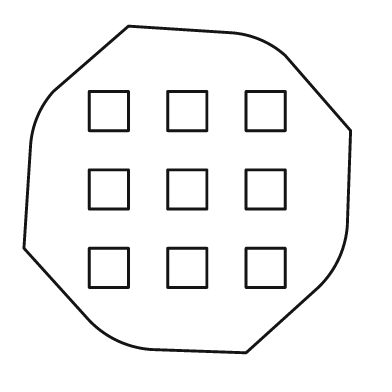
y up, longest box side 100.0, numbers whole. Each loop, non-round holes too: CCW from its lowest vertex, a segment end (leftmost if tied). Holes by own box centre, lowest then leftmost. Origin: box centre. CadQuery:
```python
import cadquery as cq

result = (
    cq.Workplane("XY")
    .moveTo(18.0, -50.0)
    .lineTo(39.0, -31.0)
    .threePointArc((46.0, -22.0), (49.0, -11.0))
    .lineTo(50.0, 18.0)
    .lineTo(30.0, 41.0)
    .threePointArc((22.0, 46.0), (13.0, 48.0))
    .lineTo(-18.0, 50.0)
    .lineTo(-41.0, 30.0)
    .threePointArc((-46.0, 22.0), (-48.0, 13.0))
    .lineTo(-50.0, -18.0)
    .lineTo(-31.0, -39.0)
    .threePointArc((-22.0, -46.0), (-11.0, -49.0))
    .close()
    .moveTo(-30.0, -30.0)
    .lineTo(-18.0, -30.0)
    .lineTo(-18.0, -18.0)
    .lineTo(-30.0, -18.0)
    .close()
    .moveTo(-6.0, -30.0)
    .lineTo(6.0, -30.0)
    .lineTo(6.0, -18.0)
    .lineTo(-6.0, -18.0)
    .close()
    .moveTo(18.0, -30.0)
    .lineTo(30.0, -30.0)
    .lineTo(30.0, -18.0)
    .lineTo(18.0, -18.0)
    .close()
    .moveTo(-30.0, -6.0)
    .lineTo(-18.0, -6.0)
    .lineTo(-18.0, 6.0)
    .lineTo(-30.0, 6.0)
    .close()
    .moveTo(-6.0, -6.0)
    .lineTo(6.0, -6.0)
    .lineTo(6.0, 6.0)
    .lineTo(-6.0, 6.0)
    .close()
    .moveTo(18.0, -6.0)
    .lineTo(30.0, -6.0)
    .lineTo(30.0, 6.0)
    .lineTo(18.0, 6.0)
    .close()
    .moveTo(-30.0, 18.0)
    .lineTo(-18.0, 18.0)
    .lineTo(-18.0, 30.0)
    .lineTo(-30.0, 30.0)
    .close()
    .moveTo(-6.0, 18.0)
    .lineTo(6.0, 18.0)
    .lineTo(6.0, 30.0)
    .lineTo(-6.0, 30.0)
    .close()
    .moveTo(18.0, 18.0)
    .lineTo(30.0, 18.0)
    .lineTo(30.0, 30.0)
    .lineTo(18.0, 30.0)
    .close()
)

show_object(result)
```